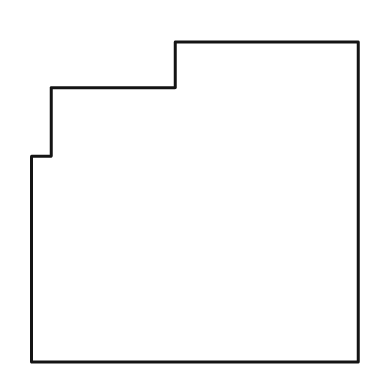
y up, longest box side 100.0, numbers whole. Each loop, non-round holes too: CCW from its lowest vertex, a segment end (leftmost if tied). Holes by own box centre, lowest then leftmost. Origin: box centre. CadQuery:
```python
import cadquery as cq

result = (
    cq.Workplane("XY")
    .moveTo(-50.0, -49.0)
    .lineTo(50.0, -49.0)
    .lineTo(50.0, 49.0)
    .lineTo(-6.0, 49.0)
    .lineTo(-6.0, 35.0)
    .lineTo(-44.0, 35.0)
    .lineTo(-44.0, 14.0)
    .lineTo(-50.0, 14.0)
    .close()
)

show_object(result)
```